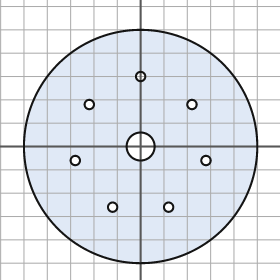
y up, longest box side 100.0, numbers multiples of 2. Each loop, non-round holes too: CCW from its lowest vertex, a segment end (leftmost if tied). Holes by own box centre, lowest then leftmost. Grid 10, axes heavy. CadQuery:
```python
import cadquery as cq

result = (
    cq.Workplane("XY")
    .moveTo(0.0, 0.0)
    .circle(50.0)
    .moveTo(-12.0, -26.0)
    .circle(2.0)
    .moveTo(12.0, -26.0)
    .circle(2.0)
    .moveTo(-28.0, -6.0)
    .circle(2.0)
    .moveTo(28.0, -6.0)
    .circle(2.0)
    .moveTo(0.0, 0.0)
    .circle(6.0)
    .moveTo(-22.0, 18.0)
    .circle(2.0)
    .moveTo(22.0, 18.0)
    .circle(2.0)
    .moveTo(0.0, 30.0)
    .circle(2.0)
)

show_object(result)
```